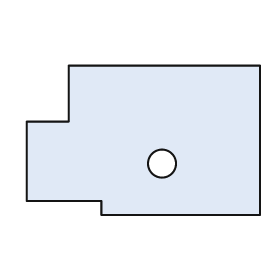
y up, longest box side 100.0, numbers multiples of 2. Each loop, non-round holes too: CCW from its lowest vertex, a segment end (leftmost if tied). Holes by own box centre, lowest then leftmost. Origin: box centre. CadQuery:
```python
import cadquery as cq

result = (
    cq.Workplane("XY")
    .moveTo(-18.0, -32.0)
    .lineTo(50.0, -32.0)
    .lineTo(50.0, 32.0)
    .lineTo(-32.0, 32.0)
    .lineTo(-32.0, 8.0)
    .lineTo(-50.0, 8.0)
    .lineTo(-50.0, -26.0)
    .lineTo(-18.0, -26.0)
    .close()
    .moveTo(8.0, -10.0)
    .circle(6.0)
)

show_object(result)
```